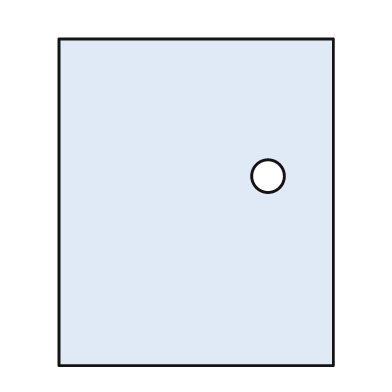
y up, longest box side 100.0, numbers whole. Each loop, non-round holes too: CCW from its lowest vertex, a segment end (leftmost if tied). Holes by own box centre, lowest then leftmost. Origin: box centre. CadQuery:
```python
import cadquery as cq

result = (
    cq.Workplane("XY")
    .moveTo(-42.0, -50.0)
    .lineTo(42.0, -50.0)
    .lineTo(42.0, 50.0)
    .lineTo(-42.0, 50.0)
    .close()
    .moveTo(22.0, 8.0)
    .circle(5.0)
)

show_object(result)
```